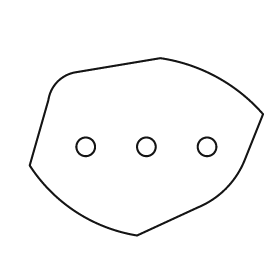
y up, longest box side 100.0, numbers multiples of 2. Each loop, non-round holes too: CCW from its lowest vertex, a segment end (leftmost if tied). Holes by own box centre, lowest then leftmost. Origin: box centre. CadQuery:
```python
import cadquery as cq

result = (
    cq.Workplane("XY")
    .moveTo(-4.0, -38.0)
    .lineTo(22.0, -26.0)
    .threePointArc((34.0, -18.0), (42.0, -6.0))
    .lineTo(50.0, 14.0)
    .threePointArc((30.0, 30.0), (6.0, 38.0))
    .lineTo(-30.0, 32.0)
    .threePointArc((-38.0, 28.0), (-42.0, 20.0))
    .lineTo(-50.0, -8.0)
    .threePointArc((-30.0, -28.0), (-4.0, -38.0))
    .close()
    .moveTo(-26.0, 0.0)
    .circle(4.0)
    .moveTo(0.0, 0.0)
    .circle(4.0)
    .moveTo(26.0, 0.0)
    .circle(4.0)
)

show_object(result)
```